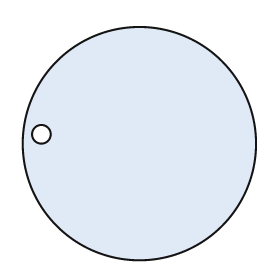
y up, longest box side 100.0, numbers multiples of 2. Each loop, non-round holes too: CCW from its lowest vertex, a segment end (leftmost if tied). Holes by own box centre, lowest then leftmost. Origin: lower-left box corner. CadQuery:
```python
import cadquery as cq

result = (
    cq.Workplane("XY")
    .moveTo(50.0, 50.0)
    .circle(50.0)
    .moveTo(8.0, 54.0)
    .circle(4.0)
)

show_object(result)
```